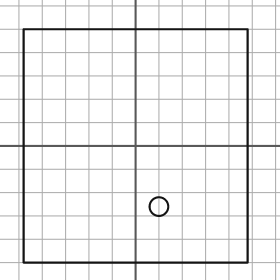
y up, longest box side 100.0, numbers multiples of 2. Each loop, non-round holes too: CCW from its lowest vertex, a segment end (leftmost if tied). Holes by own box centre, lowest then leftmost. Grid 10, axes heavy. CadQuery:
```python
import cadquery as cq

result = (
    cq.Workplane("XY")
    .moveTo(-48.0, -50.0)
    .lineTo(48.0, -50.0)
    .lineTo(48.0, 50.0)
    .lineTo(-48.0, 50.0)
    .close()
    .moveTo(10.0, -26.0)
    .circle(4.0)
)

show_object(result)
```